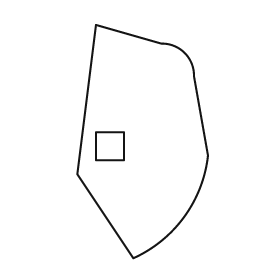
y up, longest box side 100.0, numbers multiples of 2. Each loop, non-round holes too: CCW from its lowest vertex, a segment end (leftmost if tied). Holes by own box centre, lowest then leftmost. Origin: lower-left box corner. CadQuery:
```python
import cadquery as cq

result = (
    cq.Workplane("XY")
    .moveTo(24.0, 0.0)
    .threePointArc((46.0, 18.0), (56.0, 44.0))
    .lineTo(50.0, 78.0)
    .threePointArc((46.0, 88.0), (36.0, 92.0))
    .lineTo(8.0, 100.0)
    .lineTo(0.0, 36.0)
    .close()
    .moveTo(8.0, 42.0)
    .lineTo(20.0, 42.0)
    .lineTo(20.0, 54.0)
    .lineTo(8.0, 54.0)
    .close()
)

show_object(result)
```